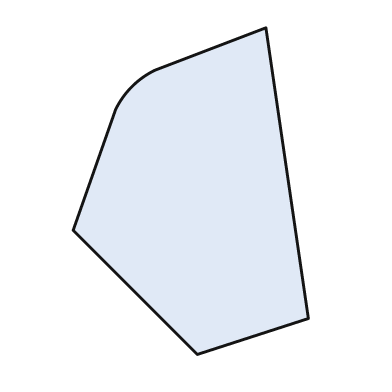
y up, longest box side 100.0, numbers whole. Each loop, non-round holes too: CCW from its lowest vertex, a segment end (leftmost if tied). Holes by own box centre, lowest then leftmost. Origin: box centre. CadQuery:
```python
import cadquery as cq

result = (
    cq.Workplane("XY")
    .moveTo(2.0, -50.0)
    .lineTo(36.0, -39.0)
    .lineTo(23.0, 50.0)
    .lineTo(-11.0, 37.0)
    .threePointArc((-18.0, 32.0), (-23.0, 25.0))
    .lineTo(-36.0, -12.0)
    .close()
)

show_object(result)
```